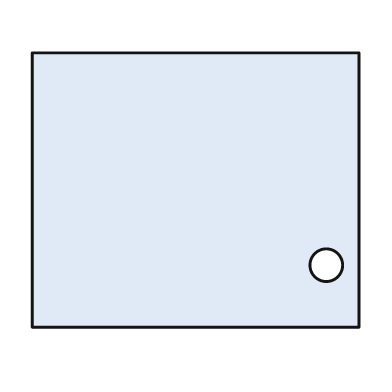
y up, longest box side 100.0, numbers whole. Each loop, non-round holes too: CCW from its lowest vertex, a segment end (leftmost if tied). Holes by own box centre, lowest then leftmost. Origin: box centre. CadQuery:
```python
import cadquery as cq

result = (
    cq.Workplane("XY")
    .moveTo(-50.0, -42.0)
    .lineTo(50.0, -42.0)
    .lineTo(50.0, 42.0)
    .lineTo(-50.0, 42.0)
    .close()
    .moveTo(40.0, -23.0)
    .circle(5.0)
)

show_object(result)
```